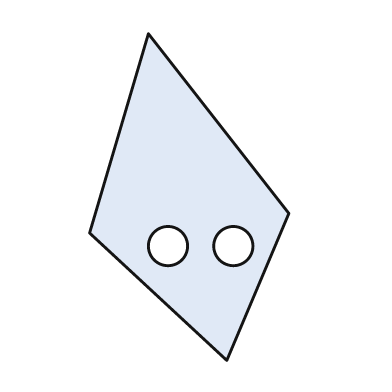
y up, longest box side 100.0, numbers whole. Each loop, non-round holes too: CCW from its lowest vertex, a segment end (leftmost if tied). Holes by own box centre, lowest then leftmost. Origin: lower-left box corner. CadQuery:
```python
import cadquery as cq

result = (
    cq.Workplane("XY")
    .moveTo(42.0, 0.0)
    .lineTo(61.0, 45.0)
    .lineTo(18.0, 100.0)
    .lineTo(0.0, 39.0)
    .close()
    .moveTo(24.0, 35.0)
    .circle(6.0)
    .moveTo(44.0, 35.0)
    .circle(6.0)
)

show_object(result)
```